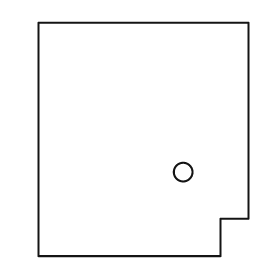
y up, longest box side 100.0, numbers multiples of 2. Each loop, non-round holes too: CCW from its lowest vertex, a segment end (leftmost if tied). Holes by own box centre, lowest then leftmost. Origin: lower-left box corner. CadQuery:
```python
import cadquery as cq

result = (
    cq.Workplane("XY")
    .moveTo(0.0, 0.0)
    .lineTo(78.0, 0.0)
    .lineTo(78.0, 16.0)
    .lineTo(90.0, 16.0)
    .lineTo(90.0, 100.0)
    .lineTo(0.0, 100.0)
    .close()
    .moveTo(62.0, 36.0)
    .circle(4.0)
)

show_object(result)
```